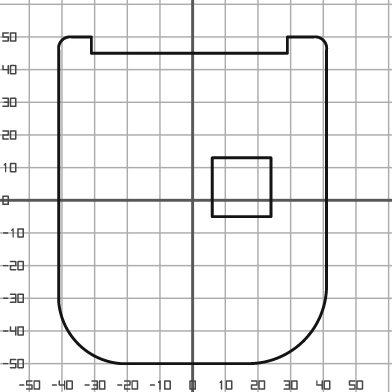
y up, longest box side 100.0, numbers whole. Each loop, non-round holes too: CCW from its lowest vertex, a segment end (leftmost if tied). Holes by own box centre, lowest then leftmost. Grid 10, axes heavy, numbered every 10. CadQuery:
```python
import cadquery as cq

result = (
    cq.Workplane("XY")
    .moveTo(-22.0, -50.0)
    .lineTo(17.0, -50.0)
    .threePointArc((34.0, -43.0), (41.0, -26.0))
    .lineTo(41.0, 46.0)
    .threePointArc((40.0, 49.0), (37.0, 50.0))
    .lineTo(29.0, 50.0)
    .lineTo(29.0, 45.0)
    .lineTo(-31.0, 45.0)
    .lineTo(-31.0, 50.0)
    .lineTo(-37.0, 50.0)
    .threePointArc((-40.0, 49.0), (-41.0, 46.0))
    .lineTo(-41.0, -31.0)
    .threePointArc((-35.0, -44.0), (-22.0, -50.0))
    .close()
    .moveTo(6.0, -5.0)
    .lineTo(24.0, -5.0)
    .lineTo(24.0, 13.0)
    .lineTo(6.0, 13.0)
    .close()
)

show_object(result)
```